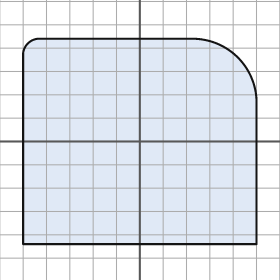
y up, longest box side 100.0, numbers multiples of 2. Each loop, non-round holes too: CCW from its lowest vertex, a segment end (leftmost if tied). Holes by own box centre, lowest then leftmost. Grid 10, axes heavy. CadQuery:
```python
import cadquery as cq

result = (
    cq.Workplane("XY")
    .moveTo(-50.0, -44.0)
    .lineTo(50.0, -44.0)
    .lineTo(50.0, 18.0)
    .threePointArc((42.0, 36.0), (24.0, 44.0))
    .lineTo(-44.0, 44.0)
    .threePointArc((-48.0, 42.0), (-50.0, 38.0))
    .close()
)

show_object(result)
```